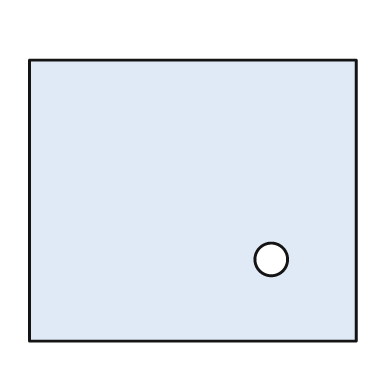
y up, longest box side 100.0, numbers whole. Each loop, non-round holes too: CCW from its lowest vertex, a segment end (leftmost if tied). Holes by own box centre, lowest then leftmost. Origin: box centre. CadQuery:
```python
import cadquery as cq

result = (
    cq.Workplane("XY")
    .moveTo(-50.0, -43.0)
    .lineTo(50.0, -43.0)
    .lineTo(50.0, 43.0)
    .lineTo(-50.0, 43.0)
    .close()
    .moveTo(24.0, -18.0)
    .circle(5.0)
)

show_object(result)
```